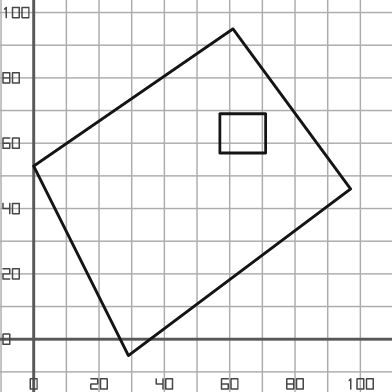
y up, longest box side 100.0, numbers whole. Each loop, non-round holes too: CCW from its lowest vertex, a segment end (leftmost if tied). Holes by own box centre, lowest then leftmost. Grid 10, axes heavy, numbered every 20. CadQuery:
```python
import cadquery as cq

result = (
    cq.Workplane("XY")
    .moveTo(29.0, -5.0)
    .lineTo(97.0, 46.0)
    .lineTo(61.0, 95.0)
    .lineTo(0.0, 53.0)
    .close()
    .moveTo(57.0, 57.0)
    .lineTo(71.0, 57.0)
    .lineTo(71.0, 69.0)
    .lineTo(57.0, 69.0)
    .close()
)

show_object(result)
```